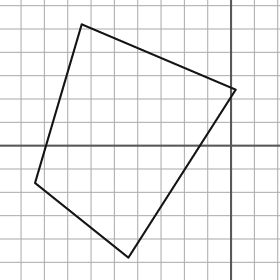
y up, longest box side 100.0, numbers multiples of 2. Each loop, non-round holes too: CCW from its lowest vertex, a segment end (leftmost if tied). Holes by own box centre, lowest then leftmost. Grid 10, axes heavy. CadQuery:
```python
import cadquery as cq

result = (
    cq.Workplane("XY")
    .moveTo(-44.0, -48.0)
    .lineTo(2.0, 24.0)
    .lineTo(-64.0, 52.0)
    .lineTo(-84.0, -16.0)
    .close()
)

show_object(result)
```